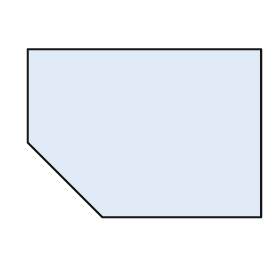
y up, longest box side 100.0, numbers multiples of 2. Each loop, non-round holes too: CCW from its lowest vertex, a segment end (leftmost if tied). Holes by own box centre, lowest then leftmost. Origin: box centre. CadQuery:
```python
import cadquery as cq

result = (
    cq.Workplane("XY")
    .moveTo(-18.0, -36.0)
    .lineTo(50.0, -36.0)
    .lineTo(50.0, 36.0)
    .lineTo(-50.0, 36.0)
    .lineTo(-50.0, -4.0)
    .close()
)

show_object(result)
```